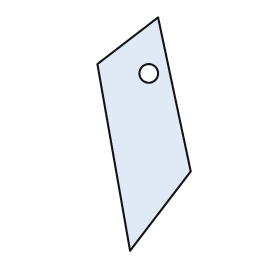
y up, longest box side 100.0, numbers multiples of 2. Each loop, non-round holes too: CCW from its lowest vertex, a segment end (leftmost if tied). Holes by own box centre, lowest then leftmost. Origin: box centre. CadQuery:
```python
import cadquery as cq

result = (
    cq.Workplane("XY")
    .moveTo(-6.0, -50.0)
    .lineTo(20.0, -16.0)
    .lineTo(6.0, 50.0)
    .lineTo(-20.0, 30.0)
    .close()
    .moveTo(2.0, 26.0)
    .circle(4.0)
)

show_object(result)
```